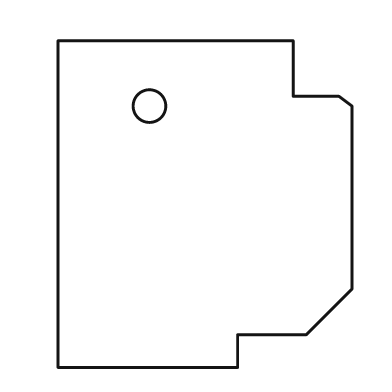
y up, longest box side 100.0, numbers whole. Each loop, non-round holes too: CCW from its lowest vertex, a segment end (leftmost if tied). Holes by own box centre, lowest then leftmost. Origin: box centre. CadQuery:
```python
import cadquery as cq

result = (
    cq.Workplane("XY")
    .moveTo(-45.0, -50.0)
    .lineTo(10.0, -50.0)
    .lineTo(10.0, -40.0)
    .lineTo(31.0, -40.0)
    .lineTo(45.0, -26.0)
    .lineTo(45.0, 30.0)
    .lineTo(41.0, 33.0)
    .lineTo(27.0, 33.0)
    .lineTo(27.0, 50.0)
    .lineTo(-45.0, 50.0)
    .close()
    .moveTo(-17.0, 30.0)
    .circle(5.0)
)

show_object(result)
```